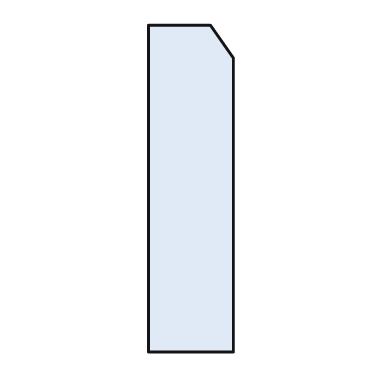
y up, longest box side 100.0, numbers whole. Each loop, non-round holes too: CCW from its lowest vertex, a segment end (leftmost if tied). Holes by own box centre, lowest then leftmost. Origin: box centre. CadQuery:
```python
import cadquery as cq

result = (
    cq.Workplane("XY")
    .moveTo(-13.0, -50.0)
    .lineTo(13.0, -50.0)
    .lineTo(13.0, 40.0)
    .lineTo(6.0, 50.0)
    .lineTo(-13.0, 50.0)
    .close()
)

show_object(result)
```